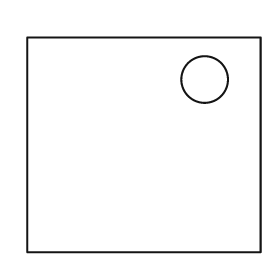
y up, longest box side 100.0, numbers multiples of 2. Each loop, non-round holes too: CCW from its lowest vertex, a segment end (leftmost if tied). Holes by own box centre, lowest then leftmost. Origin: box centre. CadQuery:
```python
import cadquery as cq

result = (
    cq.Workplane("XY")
    .moveTo(-50.0, -46.0)
    .lineTo(50.0, -46.0)
    .lineTo(50.0, 46.0)
    .lineTo(-50.0, 46.0)
    .close()
    .moveTo(26.0, 28.0)
    .circle(10.0)
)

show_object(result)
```